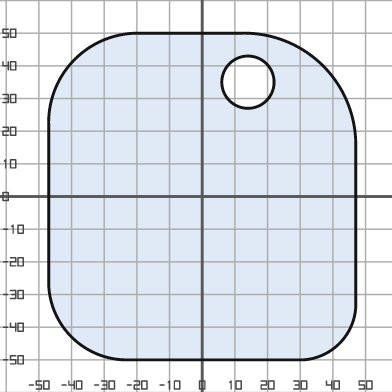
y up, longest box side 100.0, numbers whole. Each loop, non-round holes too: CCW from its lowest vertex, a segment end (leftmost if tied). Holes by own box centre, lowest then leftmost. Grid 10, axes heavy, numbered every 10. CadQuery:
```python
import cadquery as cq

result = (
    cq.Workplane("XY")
    .moveTo(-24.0, -50.0)
    .lineTo(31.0, -50.0)
    .threePointArc((42.0, -45.0), (47.0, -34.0))
    .lineTo(47.0, 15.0)
    .threePointArc((37.0, 40.0), (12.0, 50.0))
    .lineTo(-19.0, 50.0)
    .threePointArc((-39.0, 42.0), (-47.0, 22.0))
    .lineTo(-47.0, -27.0)
    .threePointArc((-40.0, -43.0), (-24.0, -50.0))
    .close()
    .moveTo(14.0, 35.0)
    .circle(8.0)
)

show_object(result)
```